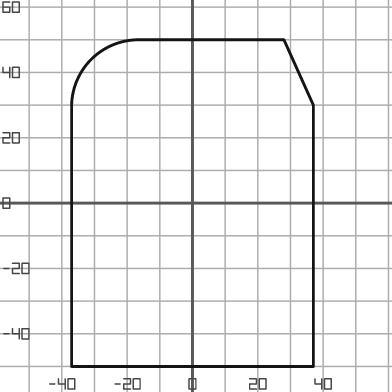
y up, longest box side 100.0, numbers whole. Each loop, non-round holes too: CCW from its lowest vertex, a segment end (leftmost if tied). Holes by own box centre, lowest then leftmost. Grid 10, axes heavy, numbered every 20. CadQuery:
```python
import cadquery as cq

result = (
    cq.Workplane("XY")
    .moveTo(-37.0, -50.0)
    .lineTo(37.0, -50.0)
    .lineTo(37.0, 30.0)
    .lineTo(28.0, 50.0)
    .lineTo(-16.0, 50.0)
    .threePointArc((-31.0, 44.0), (-37.0, 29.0))
    .close()
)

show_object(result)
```